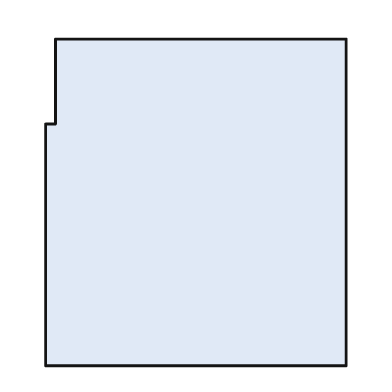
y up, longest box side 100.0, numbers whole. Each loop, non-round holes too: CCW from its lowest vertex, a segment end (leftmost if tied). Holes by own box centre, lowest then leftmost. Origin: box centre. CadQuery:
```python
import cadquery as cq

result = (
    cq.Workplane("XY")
    .moveTo(-46.0, -50.0)
    .lineTo(46.0, -50.0)
    .lineTo(46.0, 50.0)
    .lineTo(-43.0, 50.0)
    .lineTo(-43.0, 24.0)
    .lineTo(-46.0, 24.0)
    .close()
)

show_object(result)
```